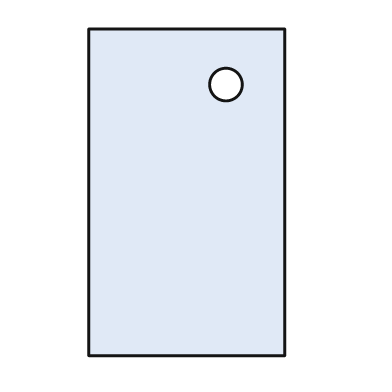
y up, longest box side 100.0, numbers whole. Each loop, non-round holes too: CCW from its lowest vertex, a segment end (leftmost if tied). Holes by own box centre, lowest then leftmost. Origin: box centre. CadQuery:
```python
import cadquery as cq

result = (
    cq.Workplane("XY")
    .moveTo(-30.0, -50.0)
    .lineTo(30.0, -50.0)
    .lineTo(30.0, 50.0)
    .lineTo(-30.0, 50.0)
    .close()
    .moveTo(12.0, 33.0)
    .circle(5.0)
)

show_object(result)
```